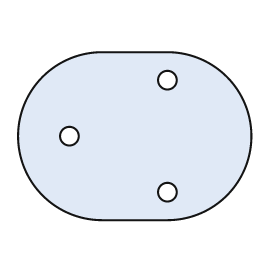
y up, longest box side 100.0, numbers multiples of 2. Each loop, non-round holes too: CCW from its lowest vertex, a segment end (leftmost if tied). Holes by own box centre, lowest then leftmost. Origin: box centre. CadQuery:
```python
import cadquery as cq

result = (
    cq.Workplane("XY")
    .moveTo(-14.0, -36.0)
    .lineTo(14.0, -36.0)
    .threePointArc((50.0, 0.0), (14.0, 36.0))
    .lineTo(-14.0, 36.0)
    .threePointArc((-50.0, 0.0), (-14.0, -36.0))
    .close()
    .moveTo(14.0, -24.0)
    .circle(4.0)
    .moveTo(-28.0, 0.0)
    .circle(4.0)
    .moveTo(14.0, 24.0)
    .circle(4.0)
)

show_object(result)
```